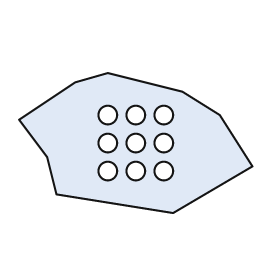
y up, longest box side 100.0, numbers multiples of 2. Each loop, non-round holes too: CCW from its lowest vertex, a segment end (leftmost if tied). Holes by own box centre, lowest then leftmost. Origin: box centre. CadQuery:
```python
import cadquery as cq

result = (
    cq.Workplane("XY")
    .moveTo(16.0, -30.0)
    .lineTo(50.0, -10.0)
    .lineTo(36.0, 12.0)
    .lineTo(20.0, 22.0)
    .lineTo(-12.0, 30.0)
    .lineTo(-26.0, 26.0)
    .lineTo(-50.0, 10.0)
    .lineTo(-38.0, -6.0)
    .lineTo(-34.0, -22.0)
    .close()
    .moveTo(-12.0, -12.0)
    .circle(4.0)
    .moveTo(0.0, -12.0)
    .circle(4.0)
    .moveTo(12.0, -12.0)
    .circle(4.0)
    .moveTo(-12.0, 0.0)
    .circle(4.0)
    .moveTo(0.0, 0.0)
    .circle(4.0)
    .moveTo(12.0, 0.0)
    .circle(4.0)
    .moveTo(-12.0, 12.0)
    .circle(4.0)
    .moveTo(0.0, 12.0)
    .circle(4.0)
    .moveTo(12.0, 12.0)
    .circle(4.0)
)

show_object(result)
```